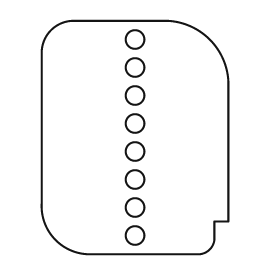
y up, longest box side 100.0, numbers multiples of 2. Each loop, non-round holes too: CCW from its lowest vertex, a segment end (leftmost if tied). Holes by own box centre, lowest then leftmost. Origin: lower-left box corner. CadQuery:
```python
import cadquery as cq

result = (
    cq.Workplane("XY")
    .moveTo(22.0, 0.0)
    .lineTo(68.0, 0.0)
    .threePointArc((72.0, 2.0), (74.0, 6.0))
    .lineTo(74.0, 14.0)
    .lineTo(80.0, 14.0)
    .lineTo(80.0, 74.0)
    .threePointArc((72.0, 92.0), (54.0, 100.0))
    .lineTo(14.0, 100.0)
    .threePointArc((4.0, 96.0), (0.0, 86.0))
    .lineTo(0.0, 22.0)
    .threePointArc((6.0, 6.0), (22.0, 0.0))
    .close()
    .moveTo(40.0, 8.0)
    .circle(4.0)
    .moveTo(40.0, 20.0)
    .circle(4.0)
    .moveTo(40.0, 32.0)
    .circle(4.0)
    .moveTo(40.0, 44.0)
    .circle(4.0)
    .moveTo(40.0, 56.0)
    .circle(4.0)
    .moveTo(40.0, 68.0)
    .circle(4.0)
    .moveTo(40.0, 80.0)
    .circle(4.0)
    .moveTo(40.0, 92.0)
    .circle(4.0)
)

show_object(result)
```